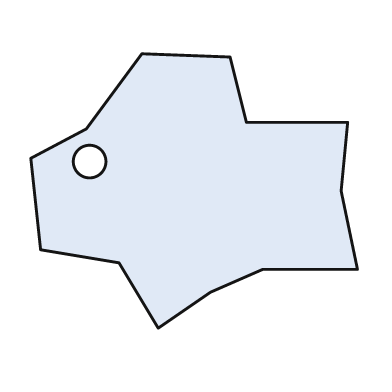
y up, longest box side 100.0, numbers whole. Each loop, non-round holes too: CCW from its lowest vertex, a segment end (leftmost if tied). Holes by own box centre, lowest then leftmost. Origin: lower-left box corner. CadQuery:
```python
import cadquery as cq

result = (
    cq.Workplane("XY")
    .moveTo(39.0, 0.0)
    .lineTo(55.0, 11.0)
    .lineTo(71.0, 18.0)
    .lineTo(100.0, 18.0)
    .lineTo(95.0, 42.0)
    .lineTo(97.0, 63.0)
    .lineTo(66.0, 63.0)
    .lineTo(61.0, 83.0)
    .lineTo(34.0, 84.0)
    .lineTo(17.0, 61.0)
    .lineTo(0.0, 52.0)
    .lineTo(3.0, 24.0)
    .lineTo(27.0, 20.0)
    .close()
    .moveTo(18.0, 51.0)
    .circle(5.0)
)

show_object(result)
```